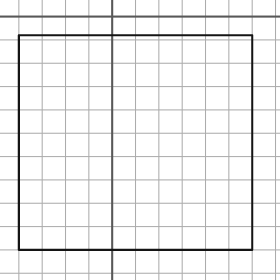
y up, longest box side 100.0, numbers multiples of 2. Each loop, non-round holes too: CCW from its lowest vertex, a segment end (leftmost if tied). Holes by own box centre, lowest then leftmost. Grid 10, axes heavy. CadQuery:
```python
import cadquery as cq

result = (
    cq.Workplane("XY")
    .moveTo(-40.0, -100.0)
    .lineTo(60.0, -100.0)
    .lineTo(60.0, -8.0)
    .lineTo(-40.0, -8.0)
    .close()
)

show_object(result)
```